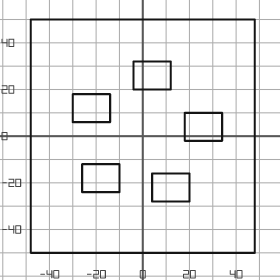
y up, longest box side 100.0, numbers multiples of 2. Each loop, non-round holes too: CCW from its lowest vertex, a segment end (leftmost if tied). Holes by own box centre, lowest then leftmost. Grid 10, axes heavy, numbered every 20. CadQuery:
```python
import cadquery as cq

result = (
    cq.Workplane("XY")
    .moveTo(-48.0, -50.0)
    .lineTo(48.0, -50.0)
    .lineTo(48.0, 50.0)
    .lineTo(-48.0, 50.0)
    .close()
    .moveTo(4.0, -28.0)
    .lineTo(20.0, -28.0)
    .lineTo(20.0, -16.0)
    .lineTo(4.0, -16.0)
    .close()
    .moveTo(-26.0, -24.0)
    .lineTo(-10.0, -24.0)
    .lineTo(-10.0, -12.0)
    .lineTo(-26.0, -12.0)
    .close()
    .moveTo(18.0, -2.0)
    .lineTo(34.0, -2.0)
    .lineTo(34.0, 10.0)
    .lineTo(18.0, 10.0)
    .close()
    .moveTo(-30.0, 6.0)
    .lineTo(-14.0, 6.0)
    .lineTo(-14.0, 18.0)
    .lineTo(-30.0, 18.0)
    .close()
    .moveTo(-4.0, 20.0)
    .lineTo(12.0, 20.0)
    .lineTo(12.0, 32.0)
    .lineTo(-4.0, 32.0)
    .close()
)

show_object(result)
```